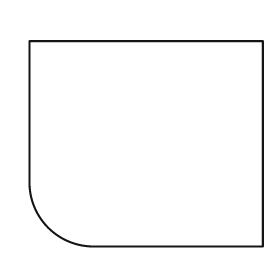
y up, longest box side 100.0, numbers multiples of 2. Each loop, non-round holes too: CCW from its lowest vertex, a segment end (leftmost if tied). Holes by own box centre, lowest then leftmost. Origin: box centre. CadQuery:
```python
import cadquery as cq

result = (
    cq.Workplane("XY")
    .moveTo(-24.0, -44.0)
    .lineTo(50.0, -44.0)
    .lineTo(50.0, 44.0)
    .lineTo(-50.0, 44.0)
    .lineTo(-50.0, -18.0)
    .threePointArc((-42.0, -36.0), (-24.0, -44.0))
    .close()
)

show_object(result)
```